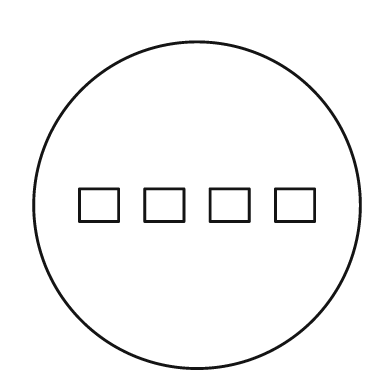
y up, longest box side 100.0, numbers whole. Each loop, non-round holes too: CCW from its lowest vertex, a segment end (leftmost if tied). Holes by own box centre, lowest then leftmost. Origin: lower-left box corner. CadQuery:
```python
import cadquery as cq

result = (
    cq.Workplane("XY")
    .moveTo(50.0, 50.0)
    .circle(50.0)
    .moveTo(14.0, 45.0)
    .lineTo(26.0, 45.0)
    .lineTo(26.0, 55.0)
    .lineTo(14.0, 55.0)
    .close()
    .moveTo(34.0, 45.0)
    .lineTo(46.0, 45.0)
    .lineTo(46.0, 55.0)
    .lineTo(34.0, 55.0)
    .close()
    .moveTo(54.0, 45.0)
    .lineTo(66.0, 45.0)
    .lineTo(66.0, 55.0)
    .lineTo(54.0, 55.0)
    .close()
    .moveTo(74.0, 45.0)
    .lineTo(86.0, 45.0)
    .lineTo(86.0, 55.0)
    .lineTo(74.0, 55.0)
    .close()
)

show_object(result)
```